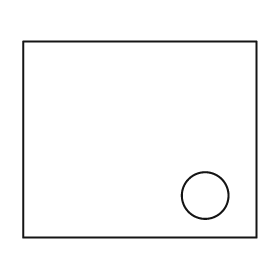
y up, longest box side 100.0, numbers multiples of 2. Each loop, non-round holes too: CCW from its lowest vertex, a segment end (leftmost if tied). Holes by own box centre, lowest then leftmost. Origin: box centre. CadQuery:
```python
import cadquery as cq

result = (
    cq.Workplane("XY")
    .moveTo(-50.0, -42.0)
    .lineTo(50.0, -42.0)
    .lineTo(50.0, 42.0)
    .lineTo(-50.0, 42.0)
    .close()
    .moveTo(28.0, -24.0)
    .circle(10.0)
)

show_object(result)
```